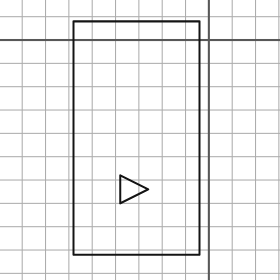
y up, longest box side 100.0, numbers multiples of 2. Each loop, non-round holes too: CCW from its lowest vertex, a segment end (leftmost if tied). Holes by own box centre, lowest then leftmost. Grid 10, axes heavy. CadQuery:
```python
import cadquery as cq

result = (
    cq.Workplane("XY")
    .moveTo(-58.0, -92.0)
    .lineTo(-4.0, -92.0)
    .lineTo(-4.0, 8.0)
    .lineTo(-58.0, 8.0)
    .close()
    .moveTo(-38.0, -70.0)
    .lineTo(-26.0, -64.0)
    .lineTo(-38.0, -58.0)
    .close()
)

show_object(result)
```